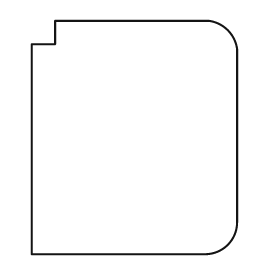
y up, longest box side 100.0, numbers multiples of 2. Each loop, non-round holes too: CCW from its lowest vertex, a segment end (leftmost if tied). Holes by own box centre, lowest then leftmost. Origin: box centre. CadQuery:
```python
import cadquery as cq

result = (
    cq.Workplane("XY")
    .moveTo(-44.0, -50.0)
    .lineTo(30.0, -50.0)
    .threePointArc((40.0, -46.0), (44.0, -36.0))
    .lineTo(44.0, 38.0)
    .threePointArc((40.0, 46.0), (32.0, 50.0))
    .lineTo(-34.0, 50.0)
    .lineTo(-34.0, 40.0)
    .lineTo(-44.0, 40.0)
    .close()
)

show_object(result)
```